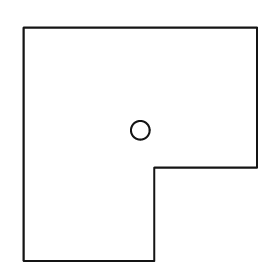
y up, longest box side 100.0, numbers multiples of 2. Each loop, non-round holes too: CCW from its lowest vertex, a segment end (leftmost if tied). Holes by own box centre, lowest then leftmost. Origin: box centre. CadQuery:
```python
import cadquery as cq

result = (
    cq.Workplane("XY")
    .moveTo(-50.0, -50.0)
    .lineTo(6.0, -50.0)
    .lineTo(6.0, -10.0)
    .lineTo(50.0, -10.0)
    .lineTo(50.0, 50.0)
    .lineTo(-50.0, 50.0)
    .close()
    .moveTo(0.0, 6.0)
    .circle(4.0)
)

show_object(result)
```